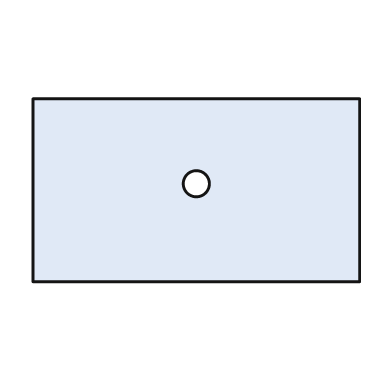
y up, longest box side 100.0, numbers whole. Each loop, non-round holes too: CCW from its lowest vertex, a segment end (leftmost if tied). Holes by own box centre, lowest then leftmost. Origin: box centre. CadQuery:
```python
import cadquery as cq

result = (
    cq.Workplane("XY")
    .moveTo(-50.0, -28.0)
    .lineTo(50.0, -28.0)
    .lineTo(50.0, 28.0)
    .lineTo(-50.0, 28.0)
    .close()
    .moveTo(0.0, 2.0)
    .circle(4.0)
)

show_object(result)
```